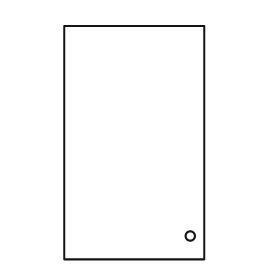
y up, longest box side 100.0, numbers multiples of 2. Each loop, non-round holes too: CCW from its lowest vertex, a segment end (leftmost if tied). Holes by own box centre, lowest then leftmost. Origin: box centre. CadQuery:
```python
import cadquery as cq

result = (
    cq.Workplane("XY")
    .moveTo(-30.0, -50.0)
    .lineTo(30.0, -50.0)
    .lineTo(30.0, 50.0)
    .lineTo(-30.0, 50.0)
    .close()
    .moveTo(24.0, -40.0)
    .circle(2.0)
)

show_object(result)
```